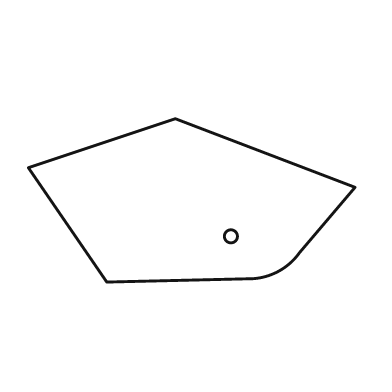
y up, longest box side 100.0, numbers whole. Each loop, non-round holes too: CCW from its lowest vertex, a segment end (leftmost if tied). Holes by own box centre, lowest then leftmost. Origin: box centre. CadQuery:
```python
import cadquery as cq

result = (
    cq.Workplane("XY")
    .moveTo(-26.0, -25.0)
    .lineTo(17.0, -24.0)
    .threePointArc((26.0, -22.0), (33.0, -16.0))
    .lineTo(50.0, 4.0)
    .lineTo(-5.0, 25.0)
    .lineTo(-50.0, 10.0)
    .close()
    .moveTo(12.0, -11.0)
    .circle(2.0)
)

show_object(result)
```